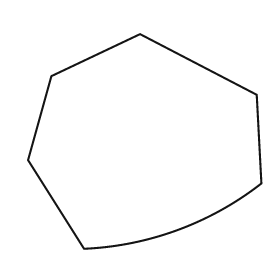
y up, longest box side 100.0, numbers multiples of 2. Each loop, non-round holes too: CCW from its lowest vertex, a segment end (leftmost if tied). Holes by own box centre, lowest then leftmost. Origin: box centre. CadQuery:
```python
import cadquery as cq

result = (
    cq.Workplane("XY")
    .moveTo(-26.0, -46.0)
    .threePointArc((14.0, -38.0), (50.0, -18.0))
    .lineTo(48.0, 20.0)
    .lineTo(-2.0, 46.0)
    .lineTo(-40.0, 28.0)
    .lineTo(-50.0, -8.0)
    .close()
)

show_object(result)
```